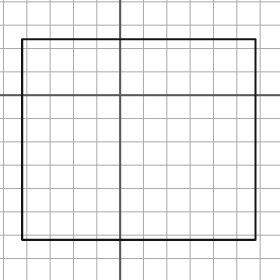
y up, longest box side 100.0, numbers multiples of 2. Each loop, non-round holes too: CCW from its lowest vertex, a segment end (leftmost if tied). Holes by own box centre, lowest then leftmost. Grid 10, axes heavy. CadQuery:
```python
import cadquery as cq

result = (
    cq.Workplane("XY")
    .moveTo(-42.0, -62.0)
    .lineTo(58.0, -62.0)
    .lineTo(58.0, 24.0)
    .lineTo(-42.0, 24.0)
    .close()
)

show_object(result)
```